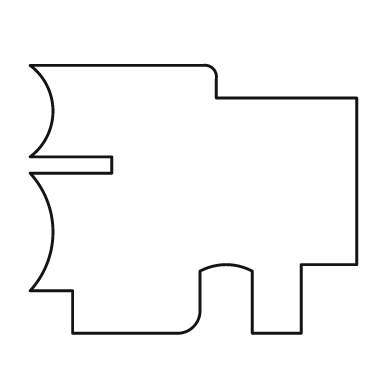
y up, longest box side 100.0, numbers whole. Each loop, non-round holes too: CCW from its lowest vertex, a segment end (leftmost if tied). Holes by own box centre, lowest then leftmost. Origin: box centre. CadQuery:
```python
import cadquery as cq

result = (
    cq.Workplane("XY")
    .moveTo(-37.0, -41.0)
    .lineTo(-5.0, -41.0)
    .threePointArc((0.0, -39.0), (2.0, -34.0))
    .lineTo(2.0, -22.0)
    .threePointArc((10.0, -20.0), (18.0, -22.0))
    .lineTo(18.0, -41.0)
    .lineTo(33.0, -41.0)
    .lineTo(33.0, -20.0)
    .lineTo(50.0, -20.0)
    .lineTo(50.0, 31.0)
    .lineTo(7.0, 31.0)
    .lineTo(7.0, 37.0)
    .threePointArc((6.0, 40.0), (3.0, 41.0))
    .lineTo(-50.0, 41.0)
    .threePointArc((-43.0, 27.0), (-50.0, 13.0))
    .lineTo(-25.0, 13.0)
    .lineTo(-25.0, 8.0)
    .lineTo(-50.0, 8.0)
    .threePointArc((-43.0, -10.0), (-50.0, -28.0))
    .lineTo(-37.0, -28.0)
    .close()
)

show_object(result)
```